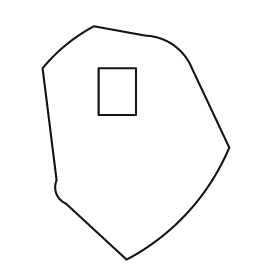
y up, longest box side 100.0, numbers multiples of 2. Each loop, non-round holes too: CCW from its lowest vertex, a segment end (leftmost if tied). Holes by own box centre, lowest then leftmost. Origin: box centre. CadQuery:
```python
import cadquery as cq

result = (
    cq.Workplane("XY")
    .moveTo(-4.0, -50.0)
    .threePointArc((22.0, -30.0), (40.0, -2.0))
    .lineTo(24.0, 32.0)
    .threePointArc((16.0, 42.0), (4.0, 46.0))
    .lineTo(-18.0, 50.0)
    .threePointArc((-30.0, 42.0), (-40.0, 32.0))
    .lineTo(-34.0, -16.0)
    .threePointArc((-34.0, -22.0), (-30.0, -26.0))
    .close()
    .moveTo(-16.0, 12.0)
    .lineTo(0.0, 12.0)
    .lineTo(0.0, 32.0)
    .lineTo(-16.0, 32.0)
    .close()
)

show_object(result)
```